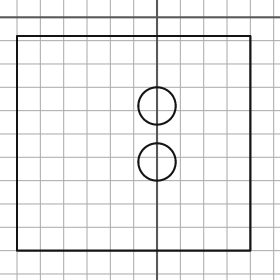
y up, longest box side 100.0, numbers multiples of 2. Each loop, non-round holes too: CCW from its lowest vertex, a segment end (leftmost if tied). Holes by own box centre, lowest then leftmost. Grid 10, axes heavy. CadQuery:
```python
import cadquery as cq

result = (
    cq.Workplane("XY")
    .moveTo(-60.0, -100.0)
    .lineTo(40.0, -100.0)
    .lineTo(40.0, -8.0)
    .lineTo(-60.0, -8.0)
    .close()
    .moveTo(0.0, -62.0)
    .circle(8.0)
    .moveTo(0.0, -38.0)
    .circle(8.0)
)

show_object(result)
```